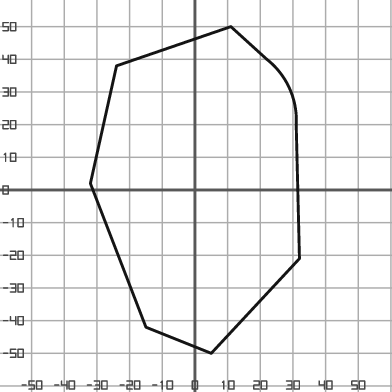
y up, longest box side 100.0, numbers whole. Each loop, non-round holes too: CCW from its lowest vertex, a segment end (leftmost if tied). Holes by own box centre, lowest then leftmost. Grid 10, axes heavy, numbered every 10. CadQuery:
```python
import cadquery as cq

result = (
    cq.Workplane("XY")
    .moveTo(5.0, -50.0)
    .lineTo(32.0, -21.0)
    .lineTo(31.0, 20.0)
    .threePointArc((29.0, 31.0), (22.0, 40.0))
    .lineTo(11.0, 50.0)
    .lineTo(-24.0, 38.0)
    .lineTo(-32.0, 2.0)
    .lineTo(-15.0, -42.0)
    .close()
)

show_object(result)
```